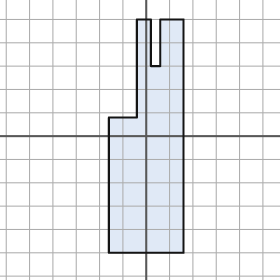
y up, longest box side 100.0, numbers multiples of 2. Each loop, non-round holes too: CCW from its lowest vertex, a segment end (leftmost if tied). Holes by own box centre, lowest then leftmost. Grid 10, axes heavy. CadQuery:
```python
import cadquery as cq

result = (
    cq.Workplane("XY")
    .moveTo(-16.0, -50.0)
    .lineTo(16.0, -50.0)
    .lineTo(16.0, 50.0)
    .lineTo(6.0, 50.0)
    .lineTo(6.0, 30.0)
    .lineTo(2.0, 30.0)
    .lineTo(2.0, 50.0)
    .lineTo(-4.0, 50.0)
    .lineTo(-4.0, 8.0)
    .lineTo(-16.0, 8.0)
    .close()
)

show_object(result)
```